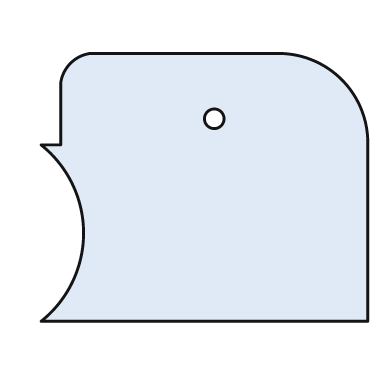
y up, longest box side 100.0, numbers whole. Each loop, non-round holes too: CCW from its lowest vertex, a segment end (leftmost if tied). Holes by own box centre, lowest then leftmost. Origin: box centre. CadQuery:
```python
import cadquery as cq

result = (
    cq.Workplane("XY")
    .moveTo(-50.0, -41.0)
    .lineTo(50.0, -41.0)
    .lineTo(50.0, 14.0)
    .threePointArc((42.0, 33.0), (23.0, 41.0))
    .lineTo(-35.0, 41.0)
    .threePointArc((-41.0, 38.0), (-44.0, 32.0))
    .lineTo(-44.0, 13.0)
    .lineTo(-50.0, 13.0)
    .threePointArc((-37.0, -14.0), (-50.0, -41.0))
    .close()
    .moveTo(3.0, 21.0)
    .circle(3.0)
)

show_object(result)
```